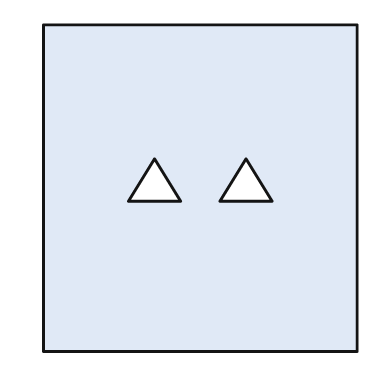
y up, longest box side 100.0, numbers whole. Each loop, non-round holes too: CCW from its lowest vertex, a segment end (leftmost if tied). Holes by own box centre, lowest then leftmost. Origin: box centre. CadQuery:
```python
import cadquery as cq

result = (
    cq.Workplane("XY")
    .moveTo(-48.0, -50.0)
    .lineTo(48.0, -50.0)
    .lineTo(48.0, 50.0)
    .lineTo(-48.0, 50.0)
    .close()
    .moveTo(-22.0, -4.0)
    .lineTo(-6.0, -4.0)
    .lineTo(-14.0, 9.0)
    .close()
    .moveTo(6.0, -4.0)
    .lineTo(22.0, -4.0)
    .lineTo(14.0, 9.0)
    .close()
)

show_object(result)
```